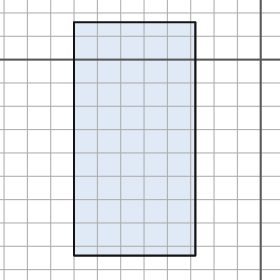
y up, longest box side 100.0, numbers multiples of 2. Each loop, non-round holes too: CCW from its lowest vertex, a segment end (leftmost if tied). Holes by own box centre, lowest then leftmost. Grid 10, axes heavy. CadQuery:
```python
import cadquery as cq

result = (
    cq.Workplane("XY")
    .moveTo(-80.0, -84.0)
    .lineTo(-28.0, -84.0)
    .lineTo(-28.0, 16.0)
    .lineTo(-80.0, 16.0)
    .close()
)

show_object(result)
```